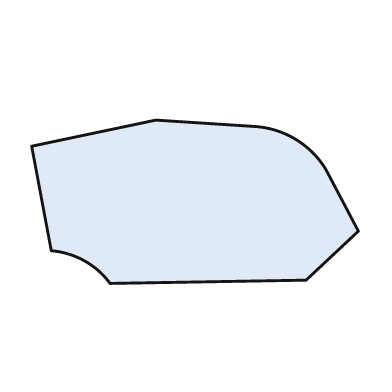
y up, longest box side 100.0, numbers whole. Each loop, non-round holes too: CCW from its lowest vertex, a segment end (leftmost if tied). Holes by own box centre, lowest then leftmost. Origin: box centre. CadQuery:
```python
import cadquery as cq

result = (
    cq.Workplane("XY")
    .moveTo(-26.0, -25.0)
    .lineTo(34.0, -24.0)
    .lineTo(50.0, -9.0)
    .lineTo(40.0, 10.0)
    .threePointArc((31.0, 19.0), (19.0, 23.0))
    .lineTo(-12.0, 25.0)
    .lineTo(-50.0, 17.0)
    .lineTo(-44.0, -15.0)
    .threePointArc((-34.0, -18.0), (-26.0, -25.0))
    .close()
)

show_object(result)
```